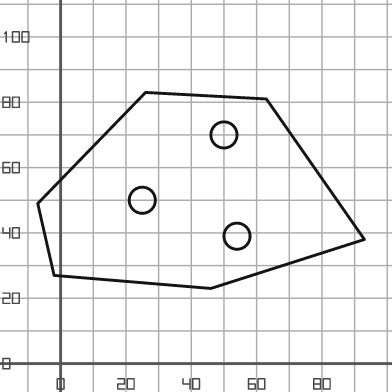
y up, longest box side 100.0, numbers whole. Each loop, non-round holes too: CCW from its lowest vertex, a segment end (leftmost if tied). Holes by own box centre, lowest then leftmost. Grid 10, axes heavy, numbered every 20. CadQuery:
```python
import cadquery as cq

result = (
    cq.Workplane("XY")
    .moveTo(46.0, 23.0)
    .lineTo(93.0, 38.0)
    .lineTo(63.0, 81.0)
    .lineTo(26.0, 83.0)
    .lineTo(-7.0, 49.0)
    .lineTo(-2.0, 27.0)
    .close()
    .moveTo(54.0, 39.0)
    .circle(4.0)
    .moveTo(25.0, 50.0)
    .circle(4.0)
    .moveTo(50.0, 70.0)
    .circle(4.0)
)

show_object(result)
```